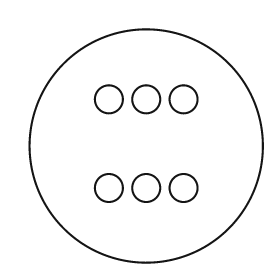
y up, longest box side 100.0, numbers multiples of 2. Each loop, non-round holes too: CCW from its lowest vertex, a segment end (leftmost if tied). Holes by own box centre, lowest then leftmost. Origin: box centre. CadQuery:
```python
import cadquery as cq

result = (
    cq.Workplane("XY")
    .moveTo(0.0, 0.0)
    .circle(50.0)
    .moveTo(-16.0, -18.0)
    .circle(6.0)
    .moveTo(0.0, -18.0)
    .circle(6.0)
    .moveTo(16.0, -18.0)
    .circle(6.0)
    .moveTo(-16.0, 20.0)
    .circle(6.0)
    .moveTo(0.0, 20.0)
    .circle(6.0)
    .moveTo(16.0, 20.0)
    .circle(6.0)
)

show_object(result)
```